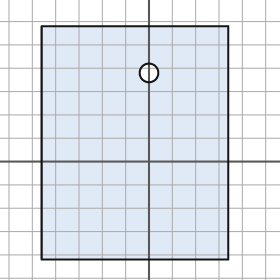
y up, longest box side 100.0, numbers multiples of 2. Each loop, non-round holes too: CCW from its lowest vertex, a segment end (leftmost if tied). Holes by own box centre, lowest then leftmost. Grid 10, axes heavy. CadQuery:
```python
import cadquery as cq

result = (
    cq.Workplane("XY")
    .moveTo(-46.0, -42.0)
    .lineTo(34.0, -42.0)
    .lineTo(34.0, 58.0)
    .lineTo(-46.0, 58.0)
    .close()
    .moveTo(0.0, 38.0)
    .circle(4.0)
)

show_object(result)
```